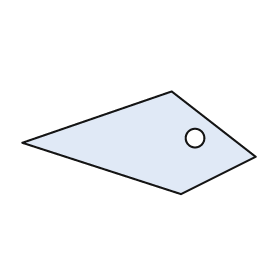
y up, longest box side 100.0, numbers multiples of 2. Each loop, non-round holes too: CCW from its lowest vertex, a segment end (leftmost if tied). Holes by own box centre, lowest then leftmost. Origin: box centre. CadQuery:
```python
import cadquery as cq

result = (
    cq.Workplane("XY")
    .moveTo(18.0, -22.0)
    .lineTo(50.0, -6.0)
    .lineTo(14.0, 22.0)
    .lineTo(-50.0, 0.0)
    .close()
    .moveTo(24.0, 2.0)
    .circle(4.0)
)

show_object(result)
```